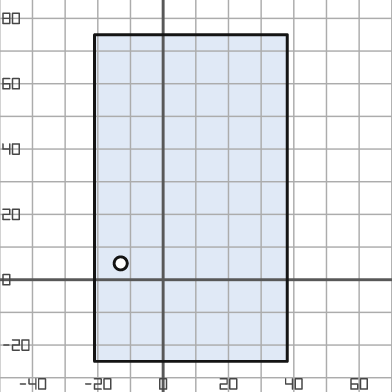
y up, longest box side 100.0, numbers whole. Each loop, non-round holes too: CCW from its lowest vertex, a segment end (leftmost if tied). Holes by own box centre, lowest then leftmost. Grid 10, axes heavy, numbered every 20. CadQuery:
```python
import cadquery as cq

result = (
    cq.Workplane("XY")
    .moveTo(-21.0, -25.0)
    .lineTo(38.0, -25.0)
    .lineTo(38.0, 75.0)
    .lineTo(-21.0, 75.0)
    .close()
    .moveTo(-13.0, 5.0)
    .circle(2.0)
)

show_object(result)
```